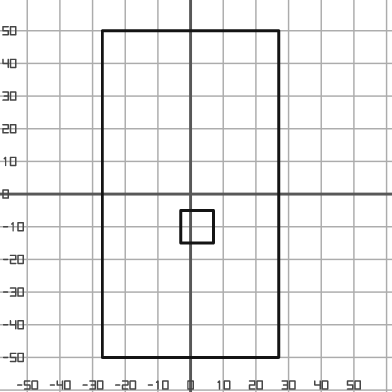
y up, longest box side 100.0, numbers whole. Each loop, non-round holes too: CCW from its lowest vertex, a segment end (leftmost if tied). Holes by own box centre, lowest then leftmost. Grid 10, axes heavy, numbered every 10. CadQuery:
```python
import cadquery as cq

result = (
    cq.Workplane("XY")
    .moveTo(-27.0, -50.0)
    .lineTo(27.0, -50.0)
    .lineTo(27.0, 50.0)
    .lineTo(-27.0, 50.0)
    .close()
    .moveTo(-3.0, -15.0)
    .lineTo(7.0, -15.0)
    .lineTo(7.0, -5.0)
    .lineTo(-3.0, -5.0)
    .close()
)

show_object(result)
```